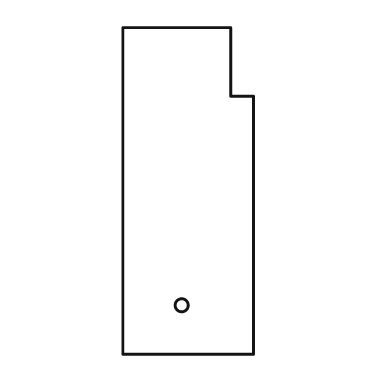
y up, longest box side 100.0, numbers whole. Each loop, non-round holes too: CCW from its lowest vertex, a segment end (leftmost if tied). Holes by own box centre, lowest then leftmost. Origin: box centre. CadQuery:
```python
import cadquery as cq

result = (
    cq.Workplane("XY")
    .moveTo(-20.0, -50.0)
    .lineTo(20.0, -50.0)
    .lineTo(20.0, 29.0)
    .lineTo(13.0, 29.0)
    .lineTo(13.0, 50.0)
    .lineTo(-20.0, 50.0)
    .close()
    .moveTo(-2.0, -35.0)
    .circle(2.0)
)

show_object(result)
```